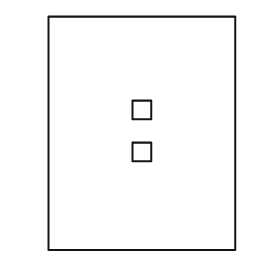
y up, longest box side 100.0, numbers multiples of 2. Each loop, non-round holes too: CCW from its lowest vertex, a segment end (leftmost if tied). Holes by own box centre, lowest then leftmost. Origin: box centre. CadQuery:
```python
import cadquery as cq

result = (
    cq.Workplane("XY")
    .moveTo(-40.0, -50.0)
    .lineTo(40.0, -50.0)
    .lineTo(40.0, 50.0)
    .lineTo(-40.0, 50.0)
    .close()
    .moveTo(-4.0, -12.0)
    .lineTo(4.0, -12.0)
    .lineTo(4.0, -4.0)
    .lineTo(-4.0, -4.0)
    .close()
    .moveTo(-4.0, 6.0)
    .lineTo(4.0, 6.0)
    .lineTo(4.0, 14.0)
    .lineTo(-4.0, 14.0)
    .close()
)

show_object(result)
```